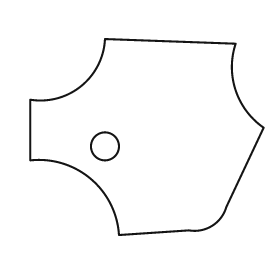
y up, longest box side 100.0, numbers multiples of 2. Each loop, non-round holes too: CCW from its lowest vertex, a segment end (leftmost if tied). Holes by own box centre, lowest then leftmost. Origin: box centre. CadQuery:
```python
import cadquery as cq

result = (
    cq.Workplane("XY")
    .moveTo(-12.0, -42.0)
    .lineTo(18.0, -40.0)
    .threePointArc((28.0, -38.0), (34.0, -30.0))
    .lineTo(50.0, 4.0)
    .threePointArc((38.0, 20.0), (38.0, 40.0))
    .lineTo(-18.0, 42.0)
    .threePointArc((-28.0, 22.0), (-50.0, 16.0))
    .lineTo(-50.0, -10.0)
    .threePointArc((-24.0, -18.0), (-12.0, -42.0))
    .close()
    .moveTo(-18.0, -4.0)
    .circle(6.0)
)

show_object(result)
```